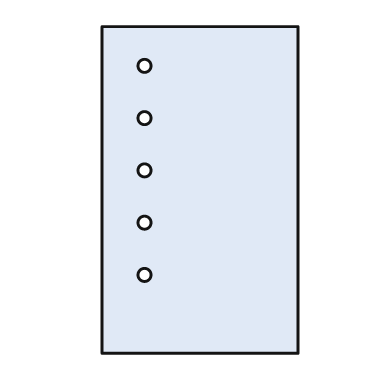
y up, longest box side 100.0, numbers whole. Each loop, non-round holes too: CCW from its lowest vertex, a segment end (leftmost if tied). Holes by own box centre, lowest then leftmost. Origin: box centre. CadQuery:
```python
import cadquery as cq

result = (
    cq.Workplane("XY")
    .moveTo(-30.0, -50.0)
    .lineTo(30.0, -50.0)
    .lineTo(30.0, 50.0)
    .lineTo(-30.0, 50.0)
    .close()
    .moveTo(-17.0, -26.0)
    .circle(2.0)
    .moveTo(-17.0, -10.0)
    .circle(2.0)
    .moveTo(-17.0, 6.0)
    .circle(2.0)
    .moveTo(-17.0, 22.0)
    .circle(2.0)
    .moveTo(-17.0, 38.0)
    .circle(2.0)
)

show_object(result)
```